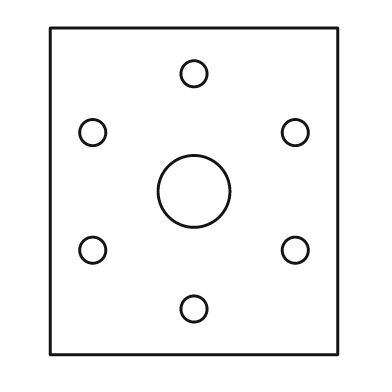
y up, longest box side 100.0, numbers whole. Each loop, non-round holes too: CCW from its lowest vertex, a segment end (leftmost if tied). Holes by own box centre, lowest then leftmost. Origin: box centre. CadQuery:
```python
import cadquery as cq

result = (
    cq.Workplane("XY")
    .moveTo(-44.0, -50.0)
    .lineTo(44.0, -50.0)
    .lineTo(44.0, 50.0)
    .lineTo(-44.0, 50.0)
    .close()
    .moveTo(0.0, -36.0)
    .circle(4.0)
    .moveTo(-31.0, -18.0)
    .circle(4.0)
    .moveTo(31.0, -18.0)
    .circle(4.0)
    .moveTo(0.0, 0.0)
    .circle(11.0)
    .moveTo(-31.0, 18.0)
    .circle(4.0)
    .moveTo(31.0, 18.0)
    .circle(4.0)
    .moveTo(0.0, 36.0)
    .circle(4.0)
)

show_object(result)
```